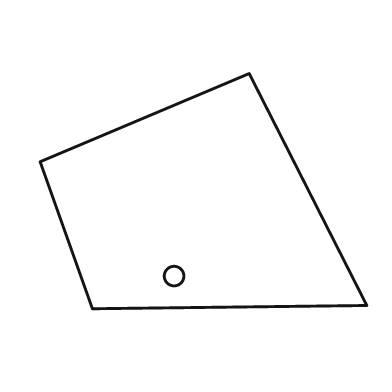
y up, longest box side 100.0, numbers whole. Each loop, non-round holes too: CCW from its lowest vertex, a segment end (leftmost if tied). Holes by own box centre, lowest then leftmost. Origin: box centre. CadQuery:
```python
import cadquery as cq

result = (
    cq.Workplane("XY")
    .moveTo(-34.0, -36.0)
    .lineTo(50.0, -35.0)
    .lineTo(14.0, 36.0)
    .lineTo(-50.0, 9.0)
    .close()
    .moveTo(-9.0, -26.0)
    .circle(3.0)
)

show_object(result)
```